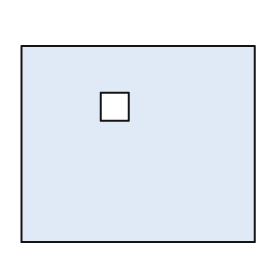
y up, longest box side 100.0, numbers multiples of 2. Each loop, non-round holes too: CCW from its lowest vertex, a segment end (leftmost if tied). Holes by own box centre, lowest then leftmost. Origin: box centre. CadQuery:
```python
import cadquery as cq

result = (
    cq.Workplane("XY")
    .moveTo(-50.0, -42.0)
    .lineTo(50.0, -42.0)
    .lineTo(50.0, 42.0)
    .lineTo(-50.0, 42.0)
    .close()
    .moveTo(-16.0, 10.0)
    .lineTo(-4.0, 10.0)
    .lineTo(-4.0, 22.0)
    .lineTo(-16.0, 22.0)
    .close()
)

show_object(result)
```